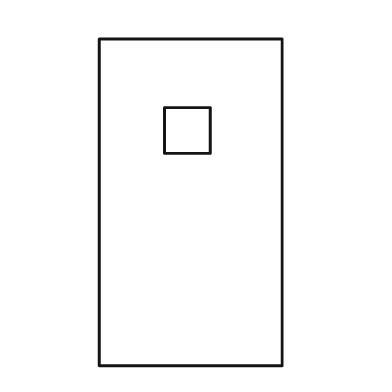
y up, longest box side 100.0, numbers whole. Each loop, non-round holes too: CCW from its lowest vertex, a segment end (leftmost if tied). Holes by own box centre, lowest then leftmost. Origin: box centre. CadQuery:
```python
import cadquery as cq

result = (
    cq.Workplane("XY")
    .moveTo(-28.0, -50.0)
    .lineTo(28.0, -50.0)
    .lineTo(28.0, 50.0)
    .lineTo(-28.0, 50.0)
    .close()
    .moveTo(-8.0, 15.0)
    .lineTo(6.0, 15.0)
    .lineTo(6.0, 29.0)
    .lineTo(-8.0, 29.0)
    .close()
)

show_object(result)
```